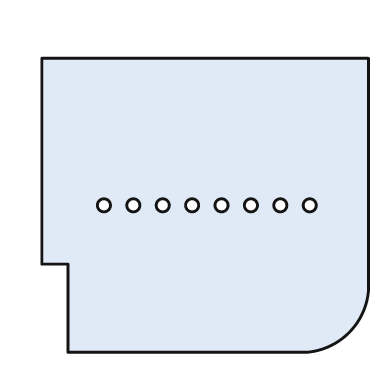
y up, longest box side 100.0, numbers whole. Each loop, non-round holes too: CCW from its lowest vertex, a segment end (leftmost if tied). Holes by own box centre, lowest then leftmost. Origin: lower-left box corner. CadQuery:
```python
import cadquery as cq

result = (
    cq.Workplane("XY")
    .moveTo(8.0, 0.0)
    .lineTo(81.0, 0.0)
    .threePointArc((94.0, 6.0), (100.0, 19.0))
    .lineTo(100.0, 90.0)
    .lineTo(0.0, 90.0)
    .lineTo(0.0, 27.0)
    .lineTo(8.0, 27.0)
    .close()
    .moveTo(19.0, 45.0)
    .circle(2.0)
    .moveTo(28.0, 45.0)
    .circle(2.0)
    .moveTo(37.0, 45.0)
    .circle(2.0)
    .moveTo(46.0, 45.0)
    .circle(2.0)
    .moveTo(55.0, 45.0)
    .circle(2.0)
    .moveTo(64.0, 45.0)
    .circle(2.0)
    .moveTo(73.0, 45.0)
    .circle(2.0)
    .moveTo(82.0, 45.0)
    .circle(2.0)
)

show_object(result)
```